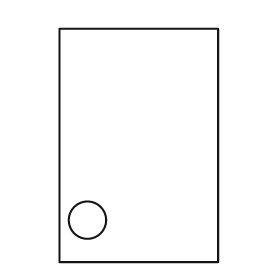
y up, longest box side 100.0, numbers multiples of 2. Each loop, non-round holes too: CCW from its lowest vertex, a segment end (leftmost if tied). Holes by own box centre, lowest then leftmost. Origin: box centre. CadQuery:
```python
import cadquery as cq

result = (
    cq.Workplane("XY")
    .moveTo(-34.0, -50.0)
    .lineTo(34.0, -50.0)
    .lineTo(34.0, 50.0)
    .lineTo(-34.0, 50.0)
    .close()
    .moveTo(-22.0, -32.0)
    .circle(8.0)
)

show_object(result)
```